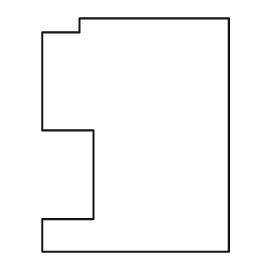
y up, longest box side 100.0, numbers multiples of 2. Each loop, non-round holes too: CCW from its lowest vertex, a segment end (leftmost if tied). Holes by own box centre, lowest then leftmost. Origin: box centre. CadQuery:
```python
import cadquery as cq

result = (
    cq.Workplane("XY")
    .moveTo(-40.0, -50.0)
    .lineTo(40.0, -50.0)
    .lineTo(40.0, 50.0)
    .lineTo(-24.0, 50.0)
    .lineTo(-24.0, 44.0)
    .lineTo(-40.0, 44.0)
    .lineTo(-40.0, 2.0)
    .lineTo(-18.0, 2.0)
    .lineTo(-18.0, -36.0)
    .lineTo(-40.0, -36.0)
    .close()
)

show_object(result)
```